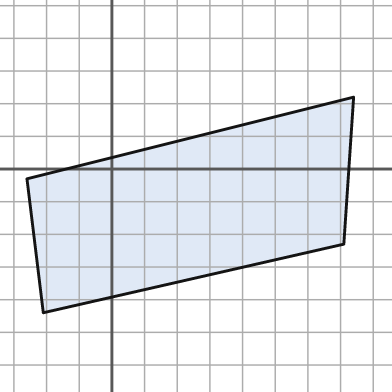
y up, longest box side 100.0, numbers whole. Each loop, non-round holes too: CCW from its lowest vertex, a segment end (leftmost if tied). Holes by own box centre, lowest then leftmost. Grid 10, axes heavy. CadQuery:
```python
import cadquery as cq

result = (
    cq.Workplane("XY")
    .moveTo(-21.0, -44.0)
    .lineTo(71.0, -23.0)
    .lineTo(74.0, 22.0)
    .lineTo(-26.0, -3.0)
    .close()
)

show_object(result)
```